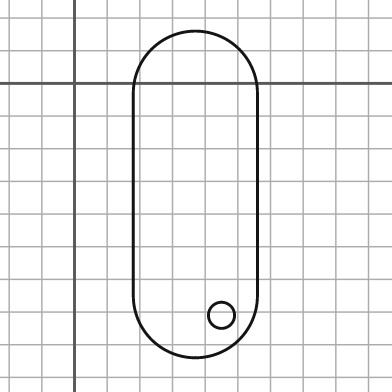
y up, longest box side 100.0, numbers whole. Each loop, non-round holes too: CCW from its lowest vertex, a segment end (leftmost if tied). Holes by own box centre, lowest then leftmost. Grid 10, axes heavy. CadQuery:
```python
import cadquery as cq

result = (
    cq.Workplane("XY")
    .moveTo(18.0, -65.0)
    .threePointArc((37.0, -84.0), (56.0, -65.0))
    .lineTo(56.0, -3.0)
    .threePointArc((37.0, 16.0), (18.0, -3.0))
    .close()
    .moveTo(45.0, -71.0)
    .circle(4.0)
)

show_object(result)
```